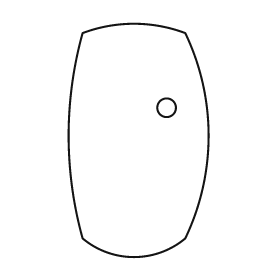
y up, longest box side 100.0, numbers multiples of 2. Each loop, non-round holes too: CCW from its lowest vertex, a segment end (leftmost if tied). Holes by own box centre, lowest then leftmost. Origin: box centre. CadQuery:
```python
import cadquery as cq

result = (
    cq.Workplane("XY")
    .moveTo(-24.0, -42.0)
    .threePointArc((-2.0, -50.0), (20.0, -42.0))
    .threePointArc((30.0, 2.0), (20.0, 46.0))
    .threePointArc((-2.0, 50.0), (-24.0, 46.0))
    .threePointArc((-30.0, 2.0), (-24.0, -42.0))
    .close()
    .moveTo(12.0, 14.0)
    .circle(4.0)
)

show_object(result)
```